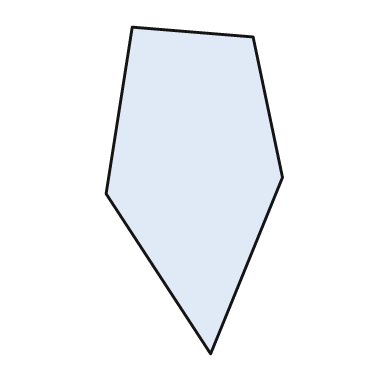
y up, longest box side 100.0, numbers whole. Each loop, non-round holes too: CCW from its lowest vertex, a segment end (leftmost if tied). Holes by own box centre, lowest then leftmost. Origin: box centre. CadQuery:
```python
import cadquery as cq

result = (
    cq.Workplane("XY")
    .moveTo(5.0, -50.0)
    .lineTo(27.0, 4.0)
    .lineTo(18.0, 47.0)
    .lineTo(-19.0, 50.0)
    .lineTo(-27.0, -1.0)
    .close()
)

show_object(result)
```